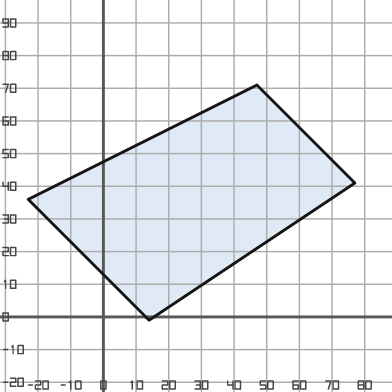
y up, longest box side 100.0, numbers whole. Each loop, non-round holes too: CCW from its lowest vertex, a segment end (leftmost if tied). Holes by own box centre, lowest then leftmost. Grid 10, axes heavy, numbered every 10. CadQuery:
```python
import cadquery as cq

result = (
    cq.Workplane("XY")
    .moveTo(14.0, -1.0)
    .lineTo(77.0, 41.0)
    .lineTo(47.0, 71.0)
    .lineTo(-23.0, 36.0)
    .close()
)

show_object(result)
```